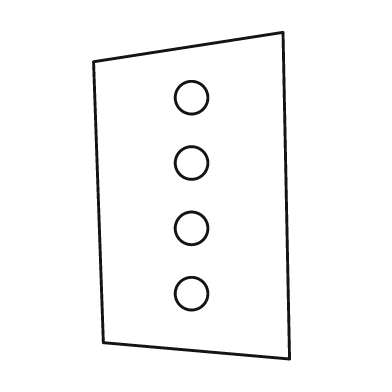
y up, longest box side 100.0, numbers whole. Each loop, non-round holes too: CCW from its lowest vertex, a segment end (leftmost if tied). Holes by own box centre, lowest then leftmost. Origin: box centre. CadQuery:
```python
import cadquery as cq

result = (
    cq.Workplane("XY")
    .moveTo(30.0, -50.0)
    .lineTo(28.0, 50.0)
    .lineTo(-30.0, 41.0)
    .lineTo(-27.0, -45.0)
    .close()
    .moveTo(0.0, -30.0)
    .circle(5.0)
    .moveTo(0.0, -10.0)
    .circle(5.0)
    .moveTo(0.0, 10.0)
    .circle(5.0)
    .moveTo(0.0, 30.0)
    .circle(5.0)
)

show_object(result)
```